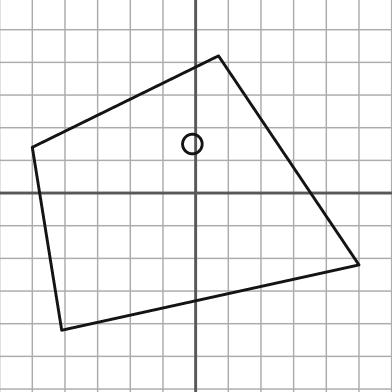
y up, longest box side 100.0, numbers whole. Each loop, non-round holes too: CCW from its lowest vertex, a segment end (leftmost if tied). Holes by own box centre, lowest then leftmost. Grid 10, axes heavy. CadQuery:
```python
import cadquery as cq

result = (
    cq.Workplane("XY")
    .moveTo(-41.0, -42.0)
    .lineTo(50.0, -22.0)
    .lineTo(7.0, 42.0)
    .lineTo(-50.0, 14.0)
    .close()
    .moveTo(-1.0, 15.0)
    .circle(3.0)
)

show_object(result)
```